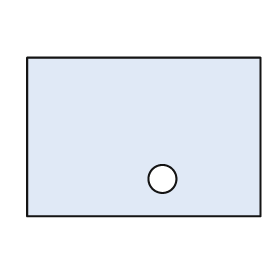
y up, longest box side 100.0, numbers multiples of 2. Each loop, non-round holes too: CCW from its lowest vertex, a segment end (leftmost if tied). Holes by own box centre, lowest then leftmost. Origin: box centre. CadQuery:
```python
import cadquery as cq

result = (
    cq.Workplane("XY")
    .moveTo(-50.0, -34.0)
    .lineTo(50.0, -34.0)
    .lineTo(50.0, 34.0)
    .lineTo(-50.0, 34.0)
    .close()
    .moveTo(8.0, -18.0)
    .circle(6.0)
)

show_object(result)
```